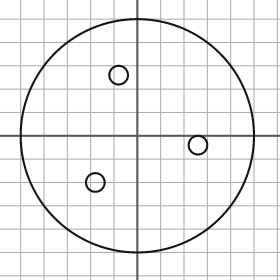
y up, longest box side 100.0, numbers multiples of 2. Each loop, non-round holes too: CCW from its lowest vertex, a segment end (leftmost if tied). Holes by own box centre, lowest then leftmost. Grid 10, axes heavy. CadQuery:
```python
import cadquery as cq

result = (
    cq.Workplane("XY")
    .moveTo(0.0, 0.0)
    .circle(50.0)
    .moveTo(-18.0, -20.0)
    .circle(4.0)
    .moveTo(26.0, -4.0)
    .circle(4.0)
    .moveTo(-8.0, 26.0)
    .circle(4.0)
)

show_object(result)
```